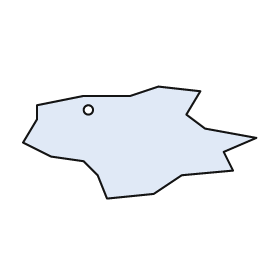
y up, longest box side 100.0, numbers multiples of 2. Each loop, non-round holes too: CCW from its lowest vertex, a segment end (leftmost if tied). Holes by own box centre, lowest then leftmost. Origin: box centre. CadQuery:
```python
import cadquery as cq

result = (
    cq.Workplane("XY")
    .moveTo(-14.0, -24.0)
    .lineTo(6.0, -22.0)
    .lineTo(18.0, -14.0)
    .lineTo(40.0, -12.0)
    .lineTo(36.0, -4.0)
    .lineTo(50.0, 2.0)
    .lineTo(28.0, 6.0)
    .lineTo(20.0, 12.0)
    .lineTo(26.0, 22.0)
    .lineTo(8.0, 24.0)
    .lineTo(-4.0, 20.0)
    .lineTo(-24.0, 20.0)
    .lineTo(-44.0, 16.0)
    .lineTo(-44.0, 10.0)
    .lineTo(-50.0, 0.0)
    .lineTo(-38.0, -6.0)
    .lineTo(-24.0, -8.0)
    .lineTo(-18.0, -14.0)
    .close()
    .moveTo(-22.0, 14.0)
    .circle(2.0)
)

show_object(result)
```